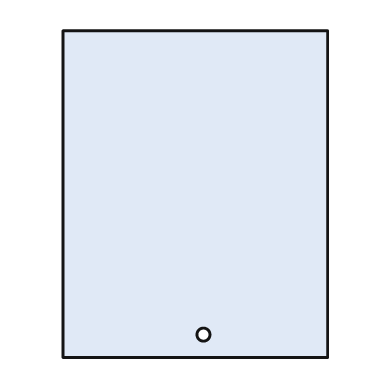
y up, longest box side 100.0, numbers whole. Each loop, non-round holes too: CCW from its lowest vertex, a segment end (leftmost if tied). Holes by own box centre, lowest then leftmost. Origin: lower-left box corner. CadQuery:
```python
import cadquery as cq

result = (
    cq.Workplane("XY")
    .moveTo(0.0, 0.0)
    .lineTo(81.0, 0.0)
    .lineTo(81.0, 100.0)
    .lineTo(0.0, 100.0)
    .close()
    .moveTo(43.0, 7.0)
    .circle(2.0)
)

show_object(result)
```